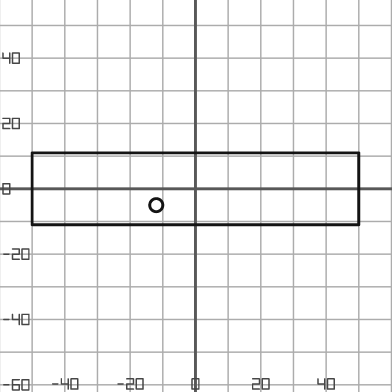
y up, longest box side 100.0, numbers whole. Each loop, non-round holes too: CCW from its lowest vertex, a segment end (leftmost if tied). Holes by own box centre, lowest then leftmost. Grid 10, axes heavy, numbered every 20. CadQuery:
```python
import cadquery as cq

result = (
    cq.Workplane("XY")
    .moveTo(-50.0, -11.0)
    .lineTo(50.0, -11.0)
    .lineTo(50.0, 11.0)
    .lineTo(-50.0, 11.0)
    .close()
    .moveTo(-12.0, -5.0)
    .circle(2.0)
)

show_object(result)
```